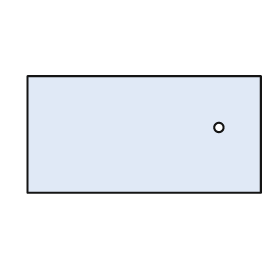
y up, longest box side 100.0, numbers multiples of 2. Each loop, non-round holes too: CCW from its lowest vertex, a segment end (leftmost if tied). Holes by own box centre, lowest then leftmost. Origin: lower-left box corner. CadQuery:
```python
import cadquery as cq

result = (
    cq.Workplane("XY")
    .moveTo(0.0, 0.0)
    .lineTo(100.0, 0.0)
    .lineTo(100.0, 50.0)
    .lineTo(0.0, 50.0)
    .close()
    .moveTo(82.0, 28.0)
    .circle(2.0)
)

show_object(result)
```